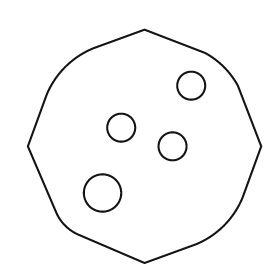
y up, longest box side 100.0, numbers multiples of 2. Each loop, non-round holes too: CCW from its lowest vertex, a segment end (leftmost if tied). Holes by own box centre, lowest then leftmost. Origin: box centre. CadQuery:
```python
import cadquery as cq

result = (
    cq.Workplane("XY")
    .moveTo(0.0, -50.0)
    .lineTo(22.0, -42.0)
    .threePointArc((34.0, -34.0), (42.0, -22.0))
    .lineTo(50.0, 0.0)
    .lineTo(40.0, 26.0)
    .threePointArc((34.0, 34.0), (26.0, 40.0))
    .lineTo(0.0, 50.0)
    .lineTo(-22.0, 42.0)
    .threePointArc((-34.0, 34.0), (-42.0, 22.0))
    .lineTo(-50.0, 0.0)
    .lineTo(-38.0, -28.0)
    .threePointArc((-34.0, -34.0), (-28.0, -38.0))
    .close()
    .moveTo(-18.0, -20.0)
    .circle(8.0)
    .moveTo(12.0, 0.0)
    .circle(6.0)
    .moveTo(-10.0, 8.0)
    .circle(6.0)
    .moveTo(20.0, 26.0)
    .circle(6.0)
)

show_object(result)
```